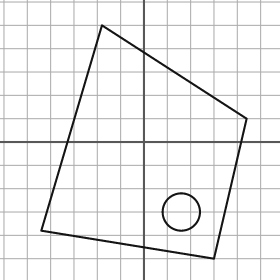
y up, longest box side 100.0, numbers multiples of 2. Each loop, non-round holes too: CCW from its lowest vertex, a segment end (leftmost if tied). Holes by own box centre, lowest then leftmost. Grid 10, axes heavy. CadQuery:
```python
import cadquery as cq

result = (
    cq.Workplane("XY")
    .moveTo(30.0, -50.0)
    .lineTo(44.0, 10.0)
    .lineTo(-18.0, 50.0)
    .lineTo(-44.0, -38.0)
    .close()
    .moveTo(16.0, -30.0)
    .circle(8.0)
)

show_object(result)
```